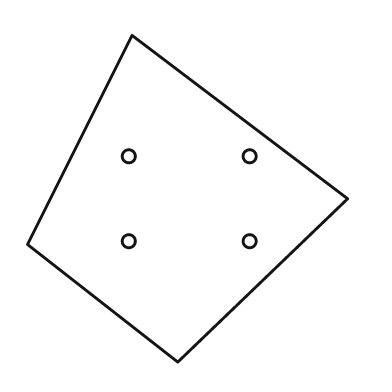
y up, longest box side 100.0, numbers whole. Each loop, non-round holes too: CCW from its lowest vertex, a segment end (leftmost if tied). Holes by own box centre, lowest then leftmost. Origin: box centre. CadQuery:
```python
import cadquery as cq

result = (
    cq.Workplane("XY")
    .moveTo(-3.0, -50.0)
    .lineTo(49.0, 0.0)
    .lineTo(-17.0, 50.0)
    .lineTo(-49.0, -14.0)
    .close()
    .moveTo(-18.0, -13.0)
    .circle(2.0)
    .moveTo(19.0, -13.0)
    .circle(2.0)
    .moveTo(-18.0, 13.0)
    .circle(2.0)
    .moveTo(19.0, 13.0)
    .circle(2.0)
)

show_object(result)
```